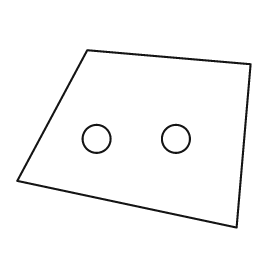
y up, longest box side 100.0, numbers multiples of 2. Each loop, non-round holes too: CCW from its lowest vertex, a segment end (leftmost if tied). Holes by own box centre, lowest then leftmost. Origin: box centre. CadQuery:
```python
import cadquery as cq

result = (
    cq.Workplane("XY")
    .moveTo(44.0, -38.0)
    .lineTo(50.0, 32.0)
    .lineTo(-20.0, 38.0)
    .lineTo(-50.0, -18.0)
    .close()
    .moveTo(-16.0, 0.0)
    .circle(6.0)
    .moveTo(18.0, 0.0)
    .circle(6.0)
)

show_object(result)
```